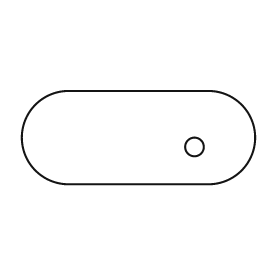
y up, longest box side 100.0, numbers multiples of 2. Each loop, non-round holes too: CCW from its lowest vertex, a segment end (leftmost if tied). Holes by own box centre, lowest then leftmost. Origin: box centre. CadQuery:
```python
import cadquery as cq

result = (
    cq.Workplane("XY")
    .moveTo(-30.0, -20.0)
    .lineTo(30.0, -20.0)
    .threePointArc((50.0, 0.0), (30.0, 20.0))
    .lineTo(-30.0, 20.0)
    .threePointArc((-50.0, 0.0), (-30.0, -20.0))
    .close()
    .moveTo(24.0, -4.0)
    .circle(4.0)
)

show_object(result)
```